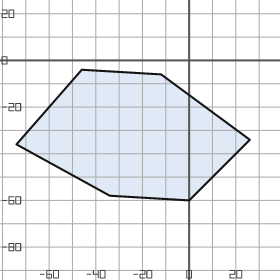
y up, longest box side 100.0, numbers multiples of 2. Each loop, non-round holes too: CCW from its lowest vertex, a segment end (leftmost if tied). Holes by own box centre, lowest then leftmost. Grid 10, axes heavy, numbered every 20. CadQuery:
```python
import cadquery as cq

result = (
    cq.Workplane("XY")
    .moveTo(0.0, -60.0)
    .lineTo(26.0, -34.0)
    .lineTo(-12.0, -6.0)
    .lineTo(-46.0, -4.0)
    .lineTo(-74.0, -36.0)
    .lineTo(-34.0, -58.0)
    .close()
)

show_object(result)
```